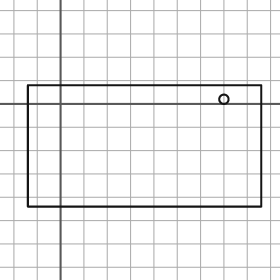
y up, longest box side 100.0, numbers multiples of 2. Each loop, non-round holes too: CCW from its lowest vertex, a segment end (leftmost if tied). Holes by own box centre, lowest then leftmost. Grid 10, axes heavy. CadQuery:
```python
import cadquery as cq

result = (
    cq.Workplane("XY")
    .moveTo(-14.0, -44.0)
    .lineTo(86.0, -44.0)
    .lineTo(86.0, 8.0)
    .lineTo(-14.0, 8.0)
    .close()
    .moveTo(70.0, 2.0)
    .circle(2.0)
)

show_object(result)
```